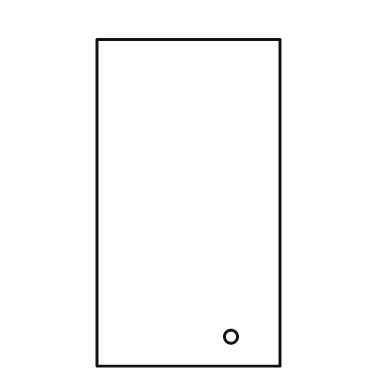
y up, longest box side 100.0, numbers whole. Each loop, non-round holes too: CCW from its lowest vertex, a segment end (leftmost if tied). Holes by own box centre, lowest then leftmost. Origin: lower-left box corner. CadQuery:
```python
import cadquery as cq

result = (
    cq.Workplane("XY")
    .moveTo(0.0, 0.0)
    .lineTo(56.0, 0.0)
    .lineTo(56.0, 100.0)
    .lineTo(0.0, 100.0)
    .close()
    .moveTo(41.0, 9.0)
    .circle(2.0)
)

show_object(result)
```